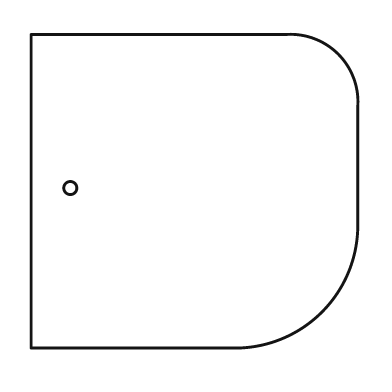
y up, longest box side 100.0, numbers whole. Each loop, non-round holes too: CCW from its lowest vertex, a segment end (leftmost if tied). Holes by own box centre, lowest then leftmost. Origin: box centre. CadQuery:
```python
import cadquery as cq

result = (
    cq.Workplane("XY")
    .moveTo(-50.0, -48.0)
    .lineTo(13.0, -48.0)
    .threePointArc((39.0, -37.0), (50.0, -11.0))
    .lineTo(50.0, 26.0)
    .threePointArc((44.0, 42.0), (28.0, 48.0))
    .lineTo(-50.0, 48.0)
    .close()
    .moveTo(-38.0, 1.0)
    .circle(2.0)
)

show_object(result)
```